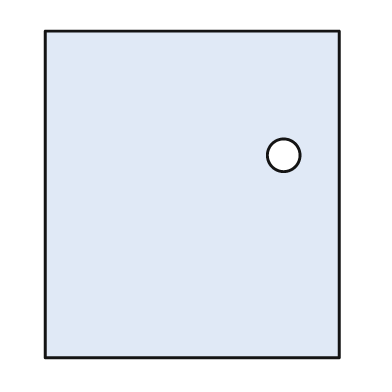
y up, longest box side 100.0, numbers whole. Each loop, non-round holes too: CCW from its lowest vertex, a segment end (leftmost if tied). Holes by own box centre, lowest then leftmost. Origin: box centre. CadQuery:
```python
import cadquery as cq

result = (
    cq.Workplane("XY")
    .moveTo(-45.0, -50.0)
    .lineTo(45.0, -50.0)
    .lineTo(45.0, 50.0)
    .lineTo(-45.0, 50.0)
    .close()
    .moveTo(28.0, 12.0)
    .circle(5.0)
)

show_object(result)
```